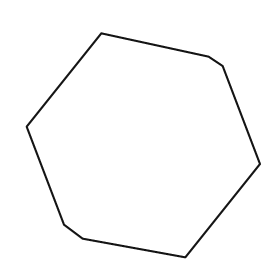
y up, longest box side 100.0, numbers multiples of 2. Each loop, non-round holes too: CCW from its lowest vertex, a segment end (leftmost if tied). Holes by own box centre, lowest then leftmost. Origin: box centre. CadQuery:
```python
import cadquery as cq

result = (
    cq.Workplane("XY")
    .moveTo(18.0, -48.0)
    .lineTo(50.0, -8.0)
    .lineTo(34.0, 34.0)
    .lineTo(28.0, 38.0)
    .lineTo(-18.0, 48.0)
    .lineTo(-50.0, 8.0)
    .lineTo(-34.0, -34.0)
    .lineTo(-26.0, -40.0)
    .close()
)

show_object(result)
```